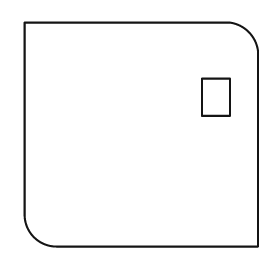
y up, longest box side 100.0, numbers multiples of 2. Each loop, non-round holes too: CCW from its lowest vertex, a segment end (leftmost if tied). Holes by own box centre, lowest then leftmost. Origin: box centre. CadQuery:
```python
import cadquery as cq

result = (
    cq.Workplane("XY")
    .moveTo(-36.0, -48.0)
    .lineTo(50.0, -48.0)
    .lineTo(50.0, 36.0)
    .threePointArc((46.0, 44.0), (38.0, 48.0))
    .lineTo(-50.0, 48.0)
    .lineTo(-50.0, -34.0)
    .threePointArc((-46.0, -44.0), (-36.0, -48.0))
    .close()
    .moveTo(26.0, 8.0)
    .lineTo(38.0, 8.0)
    .lineTo(38.0, 24.0)
    .lineTo(26.0, 24.0)
    .close()
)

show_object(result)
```